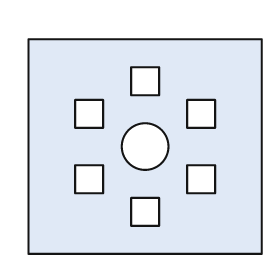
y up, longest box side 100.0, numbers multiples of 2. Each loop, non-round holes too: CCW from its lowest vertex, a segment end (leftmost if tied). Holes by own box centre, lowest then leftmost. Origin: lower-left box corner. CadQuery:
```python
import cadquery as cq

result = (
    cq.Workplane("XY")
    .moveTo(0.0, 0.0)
    .lineTo(100.0, 0.0)
    .lineTo(100.0, 92.0)
    .lineTo(0.0, 92.0)
    .close()
    .moveTo(44.0, 12.0)
    .lineTo(56.0, 12.0)
    .lineTo(56.0, 24.0)
    .lineTo(44.0, 24.0)
    .close()
    .moveTo(20.0, 26.0)
    .lineTo(32.0, 26.0)
    .lineTo(32.0, 38.0)
    .lineTo(20.0, 38.0)
    .close()
    .moveTo(68.0, 26.0)
    .lineTo(80.0, 26.0)
    .lineTo(80.0, 38.0)
    .lineTo(68.0, 38.0)
    .close()
    .moveTo(50.0, 46.0)
    .circle(10.0)
    .moveTo(20.0, 54.0)
    .lineTo(32.0, 54.0)
    .lineTo(32.0, 66.0)
    .lineTo(20.0, 66.0)
    .close()
    .moveTo(68.0, 54.0)
    .lineTo(80.0, 54.0)
    .lineTo(80.0, 66.0)
    .lineTo(68.0, 66.0)
    .close()
    .moveTo(44.0, 68.0)
    .lineTo(56.0, 68.0)
    .lineTo(56.0, 80.0)
    .lineTo(44.0, 80.0)
    .close()
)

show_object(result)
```